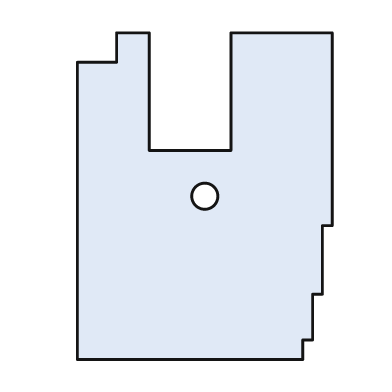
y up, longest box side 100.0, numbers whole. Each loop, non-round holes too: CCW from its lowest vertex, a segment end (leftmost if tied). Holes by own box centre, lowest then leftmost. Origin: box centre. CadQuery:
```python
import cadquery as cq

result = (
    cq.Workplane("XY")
    .moveTo(-39.0, -50.0)
    .lineTo(30.0, -50.0)
    .lineTo(30.0, -44.0)
    .lineTo(33.0, -44.0)
    .lineTo(33.0, -30.0)
    .lineTo(36.0, -30.0)
    .lineTo(36.0, -9.0)
    .lineTo(39.0, -9.0)
    .lineTo(39.0, 50.0)
    .lineTo(8.0, 50.0)
    .lineTo(8.0, 14.0)
    .lineTo(-17.0, 14.0)
    .lineTo(-17.0, 50.0)
    .lineTo(-27.0, 50.0)
    .lineTo(-27.0, 41.0)
    .lineTo(-39.0, 41.0)
    .close()
    .moveTo(0.0, 0.0)
    .circle(4.0)
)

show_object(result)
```